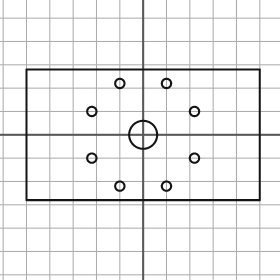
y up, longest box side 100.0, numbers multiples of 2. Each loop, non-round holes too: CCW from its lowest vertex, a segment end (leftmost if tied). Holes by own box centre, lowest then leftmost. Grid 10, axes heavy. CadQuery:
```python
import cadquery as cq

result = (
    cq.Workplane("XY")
    .moveTo(-50.0, -28.0)
    .lineTo(50.0, -28.0)
    .lineTo(50.0, 28.0)
    .lineTo(-50.0, 28.0)
    .close()
    .moveTo(-10.0, -22.0)
    .circle(2.0)
    .moveTo(10.0, -22.0)
    .circle(2.0)
    .moveTo(-22.0, -10.0)
    .circle(2.0)
    .moveTo(22.0, -10.0)
    .circle(2.0)
    .moveTo(0.0, 0.0)
    .circle(6.0)
    .moveTo(-22.0, 10.0)
    .circle(2.0)
    .moveTo(22.0, 10.0)
    .circle(2.0)
    .moveTo(-10.0, 22.0)
    .circle(2.0)
    .moveTo(10.0, 22.0)
    .circle(2.0)
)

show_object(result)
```